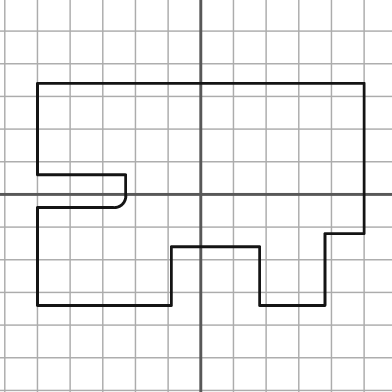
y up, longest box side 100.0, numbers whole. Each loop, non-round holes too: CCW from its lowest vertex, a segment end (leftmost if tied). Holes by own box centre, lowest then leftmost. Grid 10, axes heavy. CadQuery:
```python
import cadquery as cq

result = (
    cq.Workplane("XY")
    .moveTo(-50.0, -34.0)
    .lineTo(-9.0, -34.0)
    .lineTo(-9.0, -16.0)
    .lineTo(18.0, -16.0)
    .lineTo(18.0, -34.0)
    .lineTo(38.0, -34.0)
    .lineTo(38.0, -12.0)
    .lineTo(50.0, -12.0)
    .lineTo(50.0, 34.0)
    .lineTo(-50.0, 34.0)
    .lineTo(-50.0, 6.0)
    .lineTo(-23.0, 6.0)
    .lineTo(-23.0, 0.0)
    .threePointArc((-24.0, -3.0), (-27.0, -4.0))
    .lineTo(-50.0, -4.0)
    .close()
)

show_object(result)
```